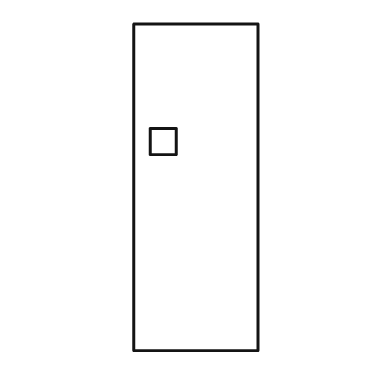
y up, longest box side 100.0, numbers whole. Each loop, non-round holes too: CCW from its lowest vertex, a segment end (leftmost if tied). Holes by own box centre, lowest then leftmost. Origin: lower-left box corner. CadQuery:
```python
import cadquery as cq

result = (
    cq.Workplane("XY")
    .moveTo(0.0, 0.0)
    .lineTo(38.0, 0.0)
    .lineTo(38.0, 100.0)
    .lineTo(0.0, 100.0)
    .close()
    .moveTo(5.0, 60.0)
    .lineTo(13.0, 60.0)
    .lineTo(13.0, 68.0)
    .lineTo(5.0, 68.0)
    .close()
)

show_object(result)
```